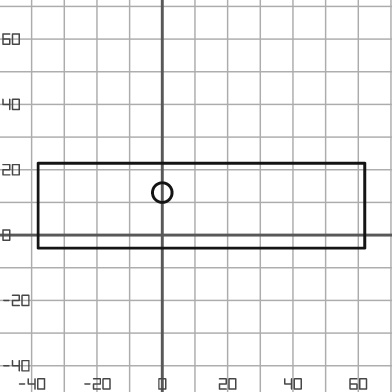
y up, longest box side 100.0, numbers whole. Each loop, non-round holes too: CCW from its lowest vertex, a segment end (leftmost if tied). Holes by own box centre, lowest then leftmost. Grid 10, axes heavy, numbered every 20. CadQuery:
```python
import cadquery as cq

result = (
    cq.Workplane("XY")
    .moveTo(-38.0, -4.0)
    .lineTo(62.0, -4.0)
    .lineTo(62.0, 22.0)
    .lineTo(-38.0, 22.0)
    .close()
    .moveTo(0.0, 13.0)
    .circle(3.0)
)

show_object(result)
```